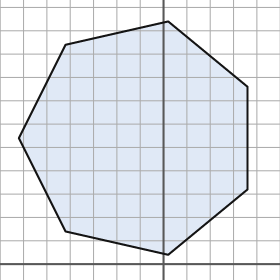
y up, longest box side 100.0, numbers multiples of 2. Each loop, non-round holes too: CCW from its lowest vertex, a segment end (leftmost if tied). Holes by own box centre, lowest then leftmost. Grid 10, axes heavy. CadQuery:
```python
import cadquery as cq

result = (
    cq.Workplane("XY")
    .moveTo(2.0, 4.0)
    .lineTo(36.0, 32.0)
    .lineTo(36.0, 76.0)
    .lineTo(2.0, 104.0)
    .lineTo(-42.0, 94.0)
    .lineTo(-62.0, 54.0)
    .lineTo(-42.0, 14.0)
    .close()
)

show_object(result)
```